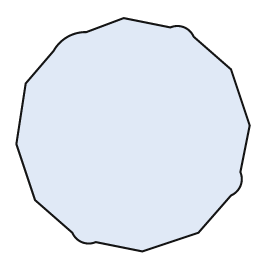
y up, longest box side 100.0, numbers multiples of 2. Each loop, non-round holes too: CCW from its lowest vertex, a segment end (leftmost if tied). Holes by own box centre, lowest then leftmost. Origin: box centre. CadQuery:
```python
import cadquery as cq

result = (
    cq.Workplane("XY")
    .moveTo(4.0, -50.0)
    .lineTo(28.0, -42.0)
    .lineTo(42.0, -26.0)
    .threePointArc((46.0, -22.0), (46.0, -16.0))
    .lineTo(50.0, 4.0)
    .lineTo(42.0, 28.0)
    .lineTo(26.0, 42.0)
    .threePointArc((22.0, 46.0), (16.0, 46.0))
    .lineTo(-4.0, 50.0)
    .lineTo(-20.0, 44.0)
    .threePointArc((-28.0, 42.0), (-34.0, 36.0))
    .lineTo(-46.0, 22.0)
    .lineTo(-50.0, -4.0)
    .lineTo(-42.0, -28.0)
    .lineTo(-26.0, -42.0)
    .threePointArc((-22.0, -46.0), (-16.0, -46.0))
    .close()
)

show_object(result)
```